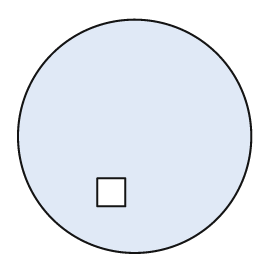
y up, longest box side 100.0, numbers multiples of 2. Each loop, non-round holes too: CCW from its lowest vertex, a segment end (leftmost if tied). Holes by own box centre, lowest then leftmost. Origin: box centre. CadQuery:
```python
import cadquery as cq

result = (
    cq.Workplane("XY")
    .moveTo(0.0, 0.0)
    .circle(50.0)
    .moveTo(-16.0, -30.0)
    .lineTo(-4.0, -30.0)
    .lineTo(-4.0, -18.0)
    .lineTo(-16.0, -18.0)
    .close()
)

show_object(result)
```